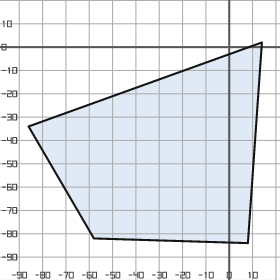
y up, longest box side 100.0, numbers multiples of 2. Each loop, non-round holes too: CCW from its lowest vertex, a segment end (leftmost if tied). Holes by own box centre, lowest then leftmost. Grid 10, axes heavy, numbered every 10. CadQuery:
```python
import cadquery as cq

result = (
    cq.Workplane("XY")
    .moveTo(8.0, -84.0)
    .lineTo(14.0, 2.0)
    .lineTo(-86.0, -34.0)
    .lineTo(-58.0, -82.0)
    .close()
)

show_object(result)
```